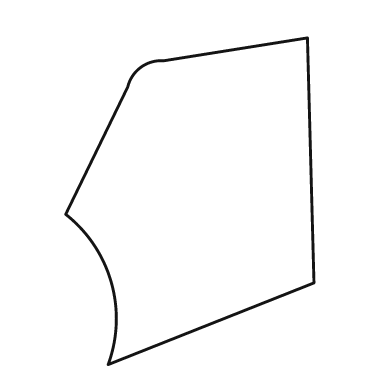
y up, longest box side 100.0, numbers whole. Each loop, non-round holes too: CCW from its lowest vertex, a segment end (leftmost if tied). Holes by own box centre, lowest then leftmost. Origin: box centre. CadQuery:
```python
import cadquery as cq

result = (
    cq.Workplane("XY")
    .moveTo(-25.0, -50.0)
    .lineTo(38.0, -25.0)
    .lineTo(36.0, 50.0)
    .lineTo(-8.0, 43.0)
    .threePointArc((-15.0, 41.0), (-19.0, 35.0))
    .lineTo(-38.0, -4.0)
    .threePointArc((-24.0, -25.0), (-25.0, -50.0))
    .close()
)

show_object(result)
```